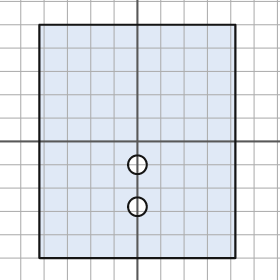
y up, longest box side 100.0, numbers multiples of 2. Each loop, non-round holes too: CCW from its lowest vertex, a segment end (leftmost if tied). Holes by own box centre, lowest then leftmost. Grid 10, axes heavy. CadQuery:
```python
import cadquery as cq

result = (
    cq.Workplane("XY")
    .moveTo(-42.0, -50.0)
    .lineTo(42.0, -50.0)
    .lineTo(42.0, 50.0)
    .lineTo(-42.0, 50.0)
    .close()
    .moveTo(0.0, -28.0)
    .circle(4.0)
    .moveTo(0.0, -10.0)
    .circle(4.0)
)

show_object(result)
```